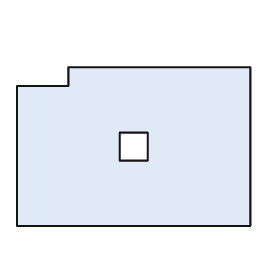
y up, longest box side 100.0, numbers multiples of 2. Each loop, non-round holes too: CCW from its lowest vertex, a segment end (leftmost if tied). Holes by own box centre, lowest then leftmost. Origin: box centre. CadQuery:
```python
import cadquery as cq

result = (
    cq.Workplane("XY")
    .moveTo(-50.0, -34.0)
    .lineTo(50.0, -34.0)
    .lineTo(50.0, 34.0)
    .lineTo(-28.0, 34.0)
    .lineTo(-28.0, 26.0)
    .lineTo(-50.0, 26.0)
    .close()
    .moveTo(-6.0, -6.0)
    .lineTo(6.0, -6.0)
    .lineTo(6.0, 6.0)
    .lineTo(-6.0, 6.0)
    .close()
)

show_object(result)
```